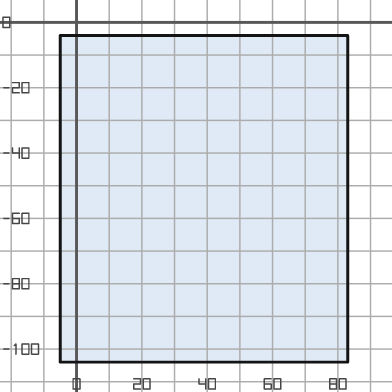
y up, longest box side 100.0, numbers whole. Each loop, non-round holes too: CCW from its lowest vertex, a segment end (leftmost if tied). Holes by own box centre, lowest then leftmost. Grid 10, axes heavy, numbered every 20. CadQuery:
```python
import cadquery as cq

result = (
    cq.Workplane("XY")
    .moveTo(-5.0, -104.0)
    .lineTo(83.0, -104.0)
    .lineTo(83.0, -4.0)
    .lineTo(-5.0, -4.0)
    .close()
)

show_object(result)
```